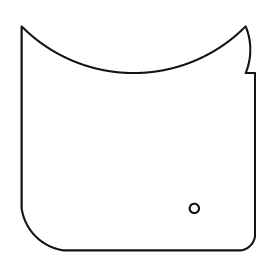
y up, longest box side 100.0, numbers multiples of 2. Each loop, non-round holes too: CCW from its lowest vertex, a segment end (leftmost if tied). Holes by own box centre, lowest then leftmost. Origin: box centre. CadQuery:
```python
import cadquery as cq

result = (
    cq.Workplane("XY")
    .moveTo(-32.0, -48.0)
    .lineTo(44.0, -48.0)
    .threePointArc((48.0, -46.0), (50.0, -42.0))
    .lineTo(50.0, 28.0)
    .lineTo(46.0, 28.0)
    .threePointArc((48.0, 38.0), (46.0, 48.0))
    .threePointArc((-2.0, 28.0), (-50.0, 48.0))
    .lineTo(-50.0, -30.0)
    .threePointArc((-44.0, -42.0), (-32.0, -48.0))
    .close()
    .moveTo(24.0, -30.0)
    .circle(2.0)
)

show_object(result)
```